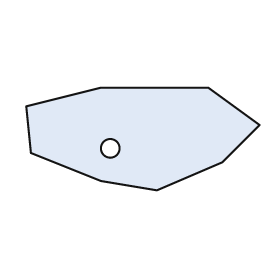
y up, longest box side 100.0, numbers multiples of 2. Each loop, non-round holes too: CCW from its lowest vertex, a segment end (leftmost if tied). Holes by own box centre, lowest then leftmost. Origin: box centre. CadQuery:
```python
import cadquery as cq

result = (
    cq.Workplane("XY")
    .moveTo(6.0, -22.0)
    .lineTo(34.0, -10.0)
    .lineTo(50.0, 6.0)
    .lineTo(28.0, 22.0)
    .lineTo(-18.0, 22.0)
    .lineTo(-50.0, 14.0)
    .lineTo(-48.0, -6.0)
    .lineTo(-18.0, -18.0)
    .close()
    .moveTo(-14.0, -4.0)
    .circle(4.0)
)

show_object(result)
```